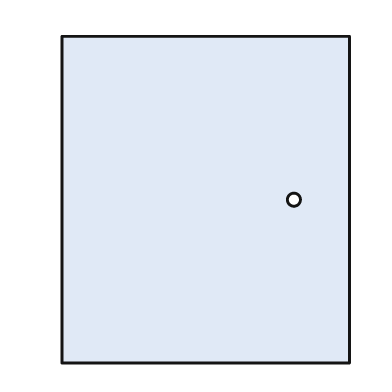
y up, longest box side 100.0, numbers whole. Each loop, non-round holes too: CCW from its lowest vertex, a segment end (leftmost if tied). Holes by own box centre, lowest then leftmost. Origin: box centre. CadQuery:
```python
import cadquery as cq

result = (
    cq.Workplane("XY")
    .moveTo(-44.0, -50.0)
    .lineTo(44.0, -50.0)
    .lineTo(44.0, 50.0)
    .lineTo(-44.0, 50.0)
    .close()
    .moveTo(27.0, 0.0)
    .circle(2.0)
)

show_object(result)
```